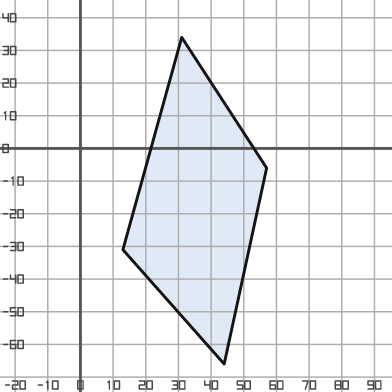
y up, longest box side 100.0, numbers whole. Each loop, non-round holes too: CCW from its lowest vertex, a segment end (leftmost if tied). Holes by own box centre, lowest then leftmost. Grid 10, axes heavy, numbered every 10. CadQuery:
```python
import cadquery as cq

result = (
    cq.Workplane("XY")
    .moveTo(44.0, -66.0)
    .lineTo(57.0, -6.0)
    .lineTo(31.0, 34.0)
    .lineTo(13.0, -31.0)
    .close()
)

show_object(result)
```